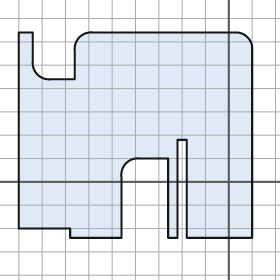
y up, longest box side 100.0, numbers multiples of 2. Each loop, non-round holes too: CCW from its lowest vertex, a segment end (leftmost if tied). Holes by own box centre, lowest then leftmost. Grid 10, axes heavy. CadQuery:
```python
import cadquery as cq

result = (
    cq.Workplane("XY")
    .moveTo(-68.0, -24.0)
    .lineTo(-46.0, -24.0)
    .lineTo(-46.0, 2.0)
    .threePointArc((-44.0, 8.0), (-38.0, 10.0))
    .lineTo(-26.0, 10.0)
    .lineTo(-26.0, -24.0)
    .lineTo(-22.0, -24.0)
    .lineTo(-22.0, 18.0)
    .lineTo(-18.0, 18.0)
    .lineTo(-18.0, -24.0)
    .lineTo(10.0, -24.0)
    .lineTo(10.0, 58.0)
    .threePointArc((8.0, 62.0), (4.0, 64.0))
    .lineTo(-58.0, 64.0)
    .threePointArc((-64.0, 62.0), (-66.0, 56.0))
    .lineTo(-66.0, 44.0)
    .lineTo(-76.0, 44.0)
    .threePointArc((-82.0, 46.0), (-84.0, 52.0))
    .lineTo(-84.0, 64.0)
    .lineTo(-90.0, 64.0)
    .lineTo(-90.0, -20.0)
    .lineTo(-68.0, -20.0)
    .close()
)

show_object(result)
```